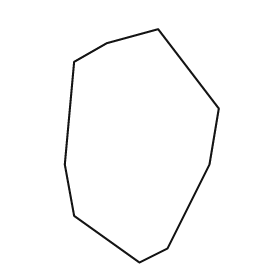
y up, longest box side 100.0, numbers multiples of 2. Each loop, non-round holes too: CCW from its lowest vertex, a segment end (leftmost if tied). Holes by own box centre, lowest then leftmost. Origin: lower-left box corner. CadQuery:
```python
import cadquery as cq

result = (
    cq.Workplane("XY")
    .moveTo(32.0, 0.0)
    .lineTo(44.0, 6.0)
    .lineTo(62.0, 42.0)
    .lineTo(66.0, 66.0)
    .lineTo(40.0, 100.0)
    .lineTo(18.0, 94.0)
    .lineTo(4.0, 86.0)
    .lineTo(0.0, 42.0)
    .lineTo(4.0, 20.0)
    .close()
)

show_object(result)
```